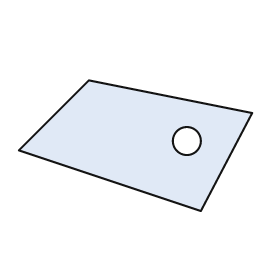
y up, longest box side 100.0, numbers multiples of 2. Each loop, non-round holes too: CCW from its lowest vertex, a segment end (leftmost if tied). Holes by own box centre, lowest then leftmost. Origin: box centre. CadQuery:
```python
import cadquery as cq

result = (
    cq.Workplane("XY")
    .moveTo(28.0, -28.0)
    .lineTo(50.0, 14.0)
    .lineTo(-20.0, 28.0)
    .lineTo(-50.0, -2.0)
    .close()
    .moveTo(22.0, 2.0)
    .circle(6.0)
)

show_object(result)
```